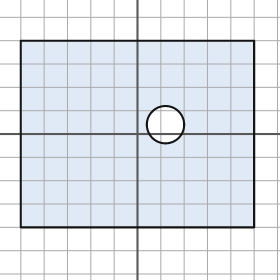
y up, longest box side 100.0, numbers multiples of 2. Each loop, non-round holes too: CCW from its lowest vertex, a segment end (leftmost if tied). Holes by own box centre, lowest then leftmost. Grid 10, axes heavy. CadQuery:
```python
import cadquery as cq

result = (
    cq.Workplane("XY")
    .moveTo(-50.0, -40.0)
    .lineTo(50.0, -40.0)
    .lineTo(50.0, 40.0)
    .lineTo(-50.0, 40.0)
    .close()
    .moveTo(12.0, 4.0)
    .circle(8.0)
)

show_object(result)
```